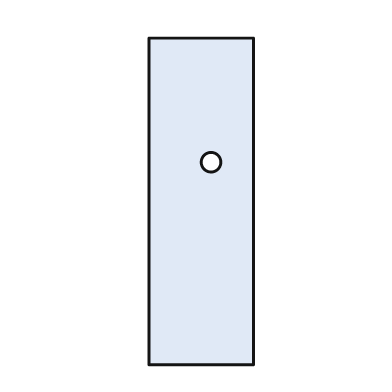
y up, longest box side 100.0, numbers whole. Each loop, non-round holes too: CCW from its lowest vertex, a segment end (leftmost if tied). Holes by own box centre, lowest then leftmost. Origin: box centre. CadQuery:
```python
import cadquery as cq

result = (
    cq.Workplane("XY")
    .moveTo(-16.0, -50.0)
    .lineTo(16.0, -50.0)
    .lineTo(16.0, 50.0)
    .lineTo(-16.0, 50.0)
    .close()
    .moveTo(3.0, 12.0)
    .circle(3.0)
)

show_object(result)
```